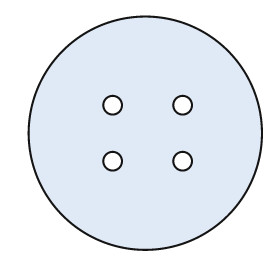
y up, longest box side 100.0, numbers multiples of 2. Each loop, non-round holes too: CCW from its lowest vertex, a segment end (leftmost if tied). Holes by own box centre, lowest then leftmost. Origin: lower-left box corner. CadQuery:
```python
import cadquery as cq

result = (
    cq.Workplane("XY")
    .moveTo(50.0, 50.0)
    .circle(50.0)
    .moveTo(36.0, 38.0)
    .circle(4.0)
    .moveTo(66.0, 38.0)
    .circle(4.0)
    .moveTo(36.0, 62.0)
    .circle(4.0)
    .moveTo(66.0, 62.0)
    .circle(4.0)
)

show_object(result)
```